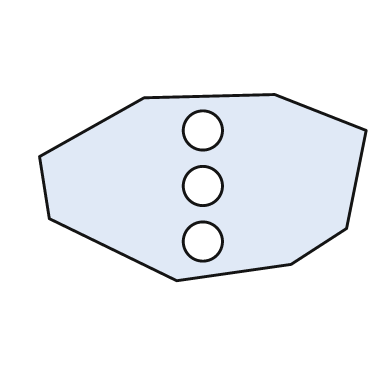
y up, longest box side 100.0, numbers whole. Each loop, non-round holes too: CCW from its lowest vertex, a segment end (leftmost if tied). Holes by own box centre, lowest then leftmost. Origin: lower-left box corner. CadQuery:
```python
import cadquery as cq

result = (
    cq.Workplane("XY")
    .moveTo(42.0, 0.0)
    .lineTo(77.0, 5.0)
    .lineTo(94.0, 16.0)
    .lineTo(100.0, 46.0)
    .lineTo(72.0, 57.0)
    .lineTo(32.0, 56.0)
    .lineTo(0.0, 38.0)
    .lineTo(3.0, 19.0)
    .close()
    .moveTo(50.0, 12.0)
    .circle(6.0)
    .moveTo(50.0, 29.0)
    .circle(6.0)
    .moveTo(50.0, 46.0)
    .circle(6.0)
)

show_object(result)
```